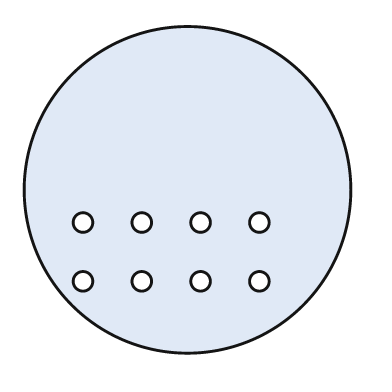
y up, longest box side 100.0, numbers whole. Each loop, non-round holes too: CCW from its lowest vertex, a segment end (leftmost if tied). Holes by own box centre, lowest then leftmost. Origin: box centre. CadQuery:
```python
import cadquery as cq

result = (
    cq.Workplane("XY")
    .moveTo(0.0, 0.0)
    .circle(50.0)
    .moveTo(-32.0, -28.0)
    .circle(3.0)
    .moveTo(-14.0, -28.0)
    .circle(3.0)
    .moveTo(4.0, -28.0)
    .circle(3.0)
    .moveTo(22.0, -28.0)
    .circle(3.0)
    .moveTo(-32.0, -10.0)
    .circle(3.0)
    .moveTo(-14.0, -10.0)
    .circle(3.0)
    .moveTo(4.0, -10.0)
    .circle(3.0)
    .moveTo(22.0, -10.0)
    .circle(3.0)
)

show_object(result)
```